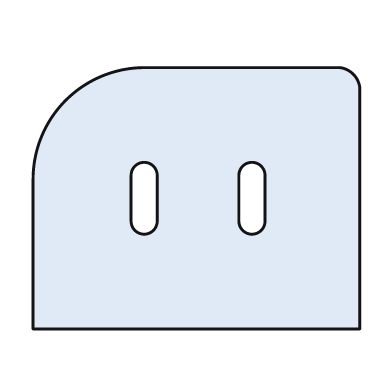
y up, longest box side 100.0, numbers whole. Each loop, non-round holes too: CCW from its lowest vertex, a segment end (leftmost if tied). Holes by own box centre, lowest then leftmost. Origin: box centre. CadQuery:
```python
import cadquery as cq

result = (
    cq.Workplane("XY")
    .moveTo(-50.0, -40.0)
    .lineTo(50.0, -40.0)
    .lineTo(50.0, 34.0)
    .threePointArc((48.0, 38.0), (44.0, 40.0))
    .lineTo(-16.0, 40.0)
    .threePointArc((-40.0, 30.0), (-50.0, 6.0))
    .close()
    .moveTo(-20.0, -7.0)
    .threePointArc((-16.0, -11.0), (-12.0, -7.0))
    .lineTo(-12.0, 7.0)
    .threePointArc((-16.0, 11.0), (-20.0, 7.0))
    .close()
    .moveTo(13.0, -7.0)
    .threePointArc((17.0, -11.0), (21.0, -7.0))
    .lineTo(21.0, 7.0)
    .threePointArc((17.0, 11.0), (13.0, 7.0))
    .close()
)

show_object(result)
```